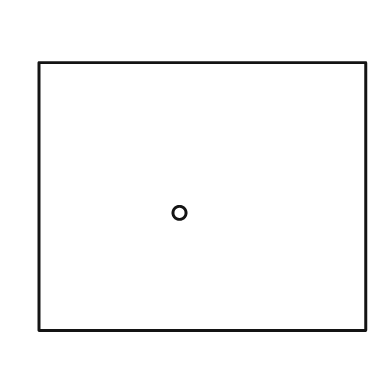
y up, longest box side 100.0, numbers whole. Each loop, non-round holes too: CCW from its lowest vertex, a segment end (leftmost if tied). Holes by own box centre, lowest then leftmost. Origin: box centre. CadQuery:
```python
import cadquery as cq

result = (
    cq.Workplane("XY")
    .moveTo(-50.0, -41.0)
    .lineTo(50.0, -41.0)
    .lineTo(50.0, 41.0)
    .lineTo(-50.0, 41.0)
    .close()
    .moveTo(-7.0, -5.0)
    .circle(2.0)
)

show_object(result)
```